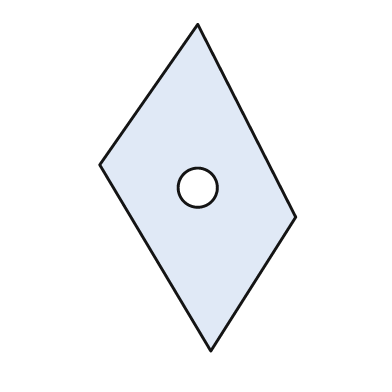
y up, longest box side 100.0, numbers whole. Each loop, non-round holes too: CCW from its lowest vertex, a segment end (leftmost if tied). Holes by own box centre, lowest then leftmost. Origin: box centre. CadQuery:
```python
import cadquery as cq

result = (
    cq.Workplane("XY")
    .moveTo(4.0, -50.0)
    .lineTo(30.0, -9.0)
    .lineTo(0.0, 50.0)
    .lineTo(-30.0, 7.0)
    .close()
    .moveTo(0.0, 0.0)
    .circle(6.0)
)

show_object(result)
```